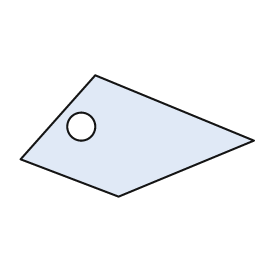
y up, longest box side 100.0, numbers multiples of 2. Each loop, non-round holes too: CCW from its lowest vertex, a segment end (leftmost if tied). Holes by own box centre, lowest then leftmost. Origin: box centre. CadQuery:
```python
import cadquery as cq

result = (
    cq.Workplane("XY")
    .moveTo(-8.0, -26.0)
    .lineTo(50.0, -2.0)
    .lineTo(-18.0, 26.0)
    .lineTo(-50.0, -10.0)
    .close()
    .moveTo(-24.0, 4.0)
    .circle(6.0)
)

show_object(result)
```